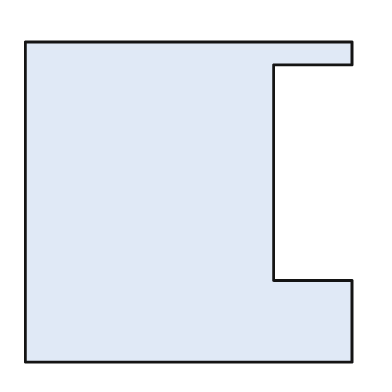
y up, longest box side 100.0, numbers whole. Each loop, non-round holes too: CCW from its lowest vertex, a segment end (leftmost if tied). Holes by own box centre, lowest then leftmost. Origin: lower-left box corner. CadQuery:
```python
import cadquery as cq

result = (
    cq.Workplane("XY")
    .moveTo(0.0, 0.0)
    .lineTo(100.0, 0.0)
    .lineTo(100.0, 25.0)
    .lineTo(76.0, 25.0)
    .lineTo(76.0, 91.0)
    .lineTo(100.0, 91.0)
    .lineTo(100.0, 98.0)
    .lineTo(0.0, 98.0)
    .close()
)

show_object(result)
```